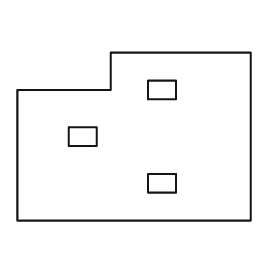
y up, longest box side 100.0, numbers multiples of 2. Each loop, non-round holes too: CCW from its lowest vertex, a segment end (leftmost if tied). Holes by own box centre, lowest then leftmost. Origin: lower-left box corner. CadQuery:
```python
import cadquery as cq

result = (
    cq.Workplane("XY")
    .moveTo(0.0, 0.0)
    .lineTo(100.0, 0.0)
    .lineTo(100.0, 72.0)
    .lineTo(40.0, 72.0)
    .lineTo(40.0, 56.0)
    .lineTo(0.0, 56.0)
    .close()
    .moveTo(56.0, 12.0)
    .lineTo(68.0, 12.0)
    .lineTo(68.0, 20.0)
    .lineTo(56.0, 20.0)
    .close()
    .moveTo(22.0, 32.0)
    .lineTo(34.0, 32.0)
    .lineTo(34.0, 40.0)
    .lineTo(22.0, 40.0)
    .close()
    .moveTo(56.0, 52.0)
    .lineTo(68.0, 52.0)
    .lineTo(68.0, 60.0)
    .lineTo(56.0, 60.0)
    .close()
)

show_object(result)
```